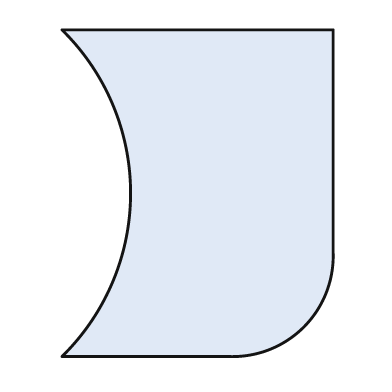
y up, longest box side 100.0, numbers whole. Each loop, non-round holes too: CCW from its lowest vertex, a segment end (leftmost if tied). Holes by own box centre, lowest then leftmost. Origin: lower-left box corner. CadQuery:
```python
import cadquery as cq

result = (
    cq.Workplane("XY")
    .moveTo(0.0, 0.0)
    .lineTo(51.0, 0.0)
    .threePointArc((74.0, 9.0), (83.0, 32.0))
    .lineTo(83.0, 100.0)
    .lineTo(0.0, 100.0)
    .threePointArc((21.0, 50.0), (0.0, 0.0))
    .close()
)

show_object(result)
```